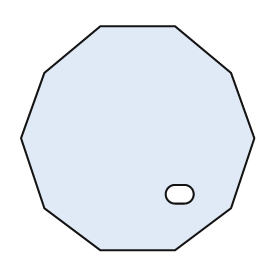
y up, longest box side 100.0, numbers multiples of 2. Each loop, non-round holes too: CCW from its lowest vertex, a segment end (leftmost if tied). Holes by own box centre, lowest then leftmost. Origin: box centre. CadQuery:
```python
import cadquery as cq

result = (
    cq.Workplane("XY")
    .moveTo(-16.0, -48.0)
    .lineTo(16.0, -48.0)
    .lineTo(40.0, -30.0)
    .lineTo(50.0, 0.0)
    .lineTo(40.0, 28.0)
    .lineTo(16.0, 48.0)
    .lineTo(-16.0, 48.0)
    .lineTo(-40.0, 28.0)
    .lineTo(-50.0, 0.0)
    .lineTo(-40.0, -30.0)
    .close()
    .moveTo(16.0, -28.0)
    .lineTo(20.0, -28.0)
    .threePointArc((24.0, -24.0), (20.0, -20.0))
    .lineTo(16.0, -20.0)
    .threePointArc((12.0, -24.0), (16.0, -28.0))
    .close()
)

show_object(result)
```